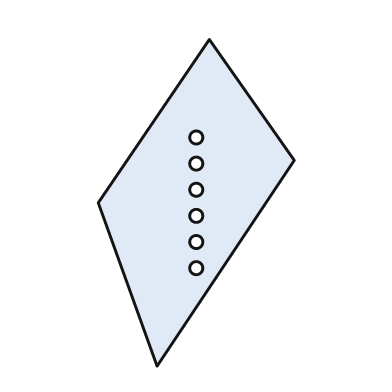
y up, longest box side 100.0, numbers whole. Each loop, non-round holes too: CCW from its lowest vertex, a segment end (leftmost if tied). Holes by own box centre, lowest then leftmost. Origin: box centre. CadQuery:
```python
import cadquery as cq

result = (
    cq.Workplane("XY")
    .moveTo(-12.0, -50.0)
    .lineTo(30.0, 13.0)
    .lineTo(4.0, 50.0)
    .lineTo(-30.0, 0.0)
    .close()
    .moveTo(0.0, -20.0)
    .circle(2.0)
    .moveTo(0.0, -12.0)
    .circle(2.0)
    .moveTo(0.0, -4.0)
    .circle(2.0)
    .moveTo(0.0, 4.0)
    .circle(2.0)
    .moveTo(0.0, 12.0)
    .circle(2.0)
    .moveTo(0.0, 20.0)
    .circle(2.0)
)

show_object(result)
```